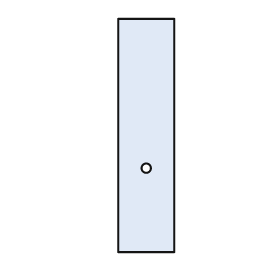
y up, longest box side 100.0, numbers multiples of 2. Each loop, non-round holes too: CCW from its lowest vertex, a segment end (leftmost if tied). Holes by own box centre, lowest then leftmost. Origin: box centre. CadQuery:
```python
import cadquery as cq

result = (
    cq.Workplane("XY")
    .moveTo(-12.0, -50.0)
    .lineTo(12.0, -50.0)
    .lineTo(12.0, 50.0)
    .lineTo(-12.0, 50.0)
    .close()
    .moveTo(0.0, -14.0)
    .circle(2.0)
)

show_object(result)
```